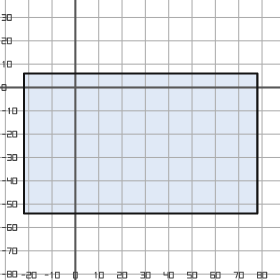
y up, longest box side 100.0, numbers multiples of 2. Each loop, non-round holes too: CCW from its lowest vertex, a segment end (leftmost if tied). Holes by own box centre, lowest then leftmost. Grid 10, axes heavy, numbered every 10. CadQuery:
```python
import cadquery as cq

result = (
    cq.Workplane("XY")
    .moveTo(-22.0, -54.0)
    .lineTo(78.0, -54.0)
    .lineTo(78.0, 6.0)
    .lineTo(-22.0, 6.0)
    .close()
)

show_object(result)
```